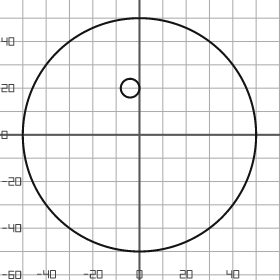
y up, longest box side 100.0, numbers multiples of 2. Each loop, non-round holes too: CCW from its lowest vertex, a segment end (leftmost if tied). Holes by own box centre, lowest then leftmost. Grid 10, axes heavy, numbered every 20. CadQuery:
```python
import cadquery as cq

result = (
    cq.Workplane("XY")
    .moveTo(0.0, 0.0)
    .circle(50.0)
    .moveTo(-4.0, 20.0)
    .circle(4.0)
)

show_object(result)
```